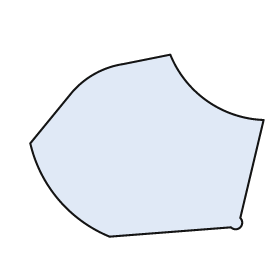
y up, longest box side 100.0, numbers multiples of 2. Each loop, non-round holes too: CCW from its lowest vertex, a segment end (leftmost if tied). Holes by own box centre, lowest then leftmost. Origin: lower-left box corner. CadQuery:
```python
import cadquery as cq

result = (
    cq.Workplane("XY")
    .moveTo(34.0, 0.0)
    .lineTo(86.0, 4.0)
    .threePointArc((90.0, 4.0), (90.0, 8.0))
    .lineTo(100.0, 50.0)
    .threePointArc((76.0, 58.0), (60.0, 78.0))
    .lineTo(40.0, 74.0)
    .threePointArc((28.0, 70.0), (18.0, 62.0))
    .lineTo(0.0, 40.0)
    .threePointArc((12.0, 16.0), (34.0, 0.0))
    .close()
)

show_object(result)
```